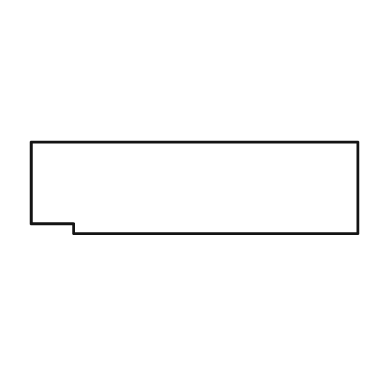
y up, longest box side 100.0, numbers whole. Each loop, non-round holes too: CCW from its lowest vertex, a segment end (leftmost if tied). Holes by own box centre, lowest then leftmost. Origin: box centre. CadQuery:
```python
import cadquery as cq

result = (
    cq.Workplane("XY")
    .moveTo(-37.0, -14.0)
    .lineTo(50.0, -14.0)
    .lineTo(50.0, 14.0)
    .lineTo(-50.0, 14.0)
    .lineTo(-50.0, -11.0)
    .lineTo(-37.0, -11.0)
    .close()
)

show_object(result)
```